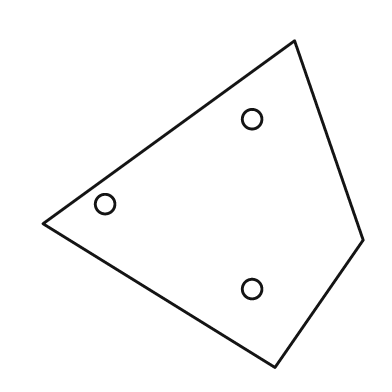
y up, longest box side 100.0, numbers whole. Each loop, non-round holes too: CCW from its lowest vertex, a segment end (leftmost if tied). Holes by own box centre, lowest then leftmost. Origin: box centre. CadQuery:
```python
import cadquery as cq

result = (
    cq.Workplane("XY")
    .moveTo(22.0, -50.0)
    .lineTo(49.0, -11.0)
    .lineTo(28.0, 50.0)
    .lineTo(-49.0, -6.0)
    .close()
    .moveTo(15.0, -26.0)
    .circle(3.0)
    .moveTo(-30.0, 0.0)
    .circle(3.0)
    .moveTo(15.0, 26.0)
    .circle(3.0)
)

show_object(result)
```